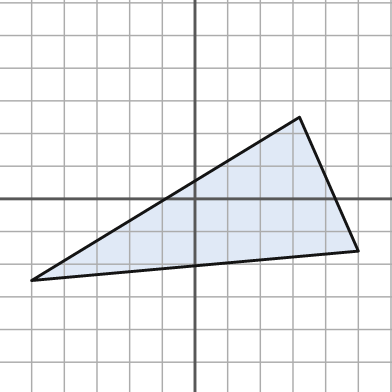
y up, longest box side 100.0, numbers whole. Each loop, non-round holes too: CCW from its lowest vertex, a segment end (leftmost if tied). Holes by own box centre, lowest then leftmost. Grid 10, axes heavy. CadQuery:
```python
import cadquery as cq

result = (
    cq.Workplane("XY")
    .moveTo(-50.0, -25.0)
    .lineTo(50.0, -16.0)
    .lineTo(32.0, 25.0)
    .close()
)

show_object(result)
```